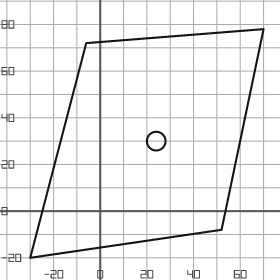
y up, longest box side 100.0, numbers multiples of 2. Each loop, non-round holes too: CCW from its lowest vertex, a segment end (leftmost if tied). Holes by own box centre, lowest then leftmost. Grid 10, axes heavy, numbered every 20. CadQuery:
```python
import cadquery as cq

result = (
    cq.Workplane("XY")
    .moveTo(-30.0, -20.0)
    .lineTo(52.0, -8.0)
    .lineTo(70.0, 78.0)
    .lineTo(-6.0, 72.0)
    .close()
    .moveTo(24.0, 30.0)
    .circle(4.0)
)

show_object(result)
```